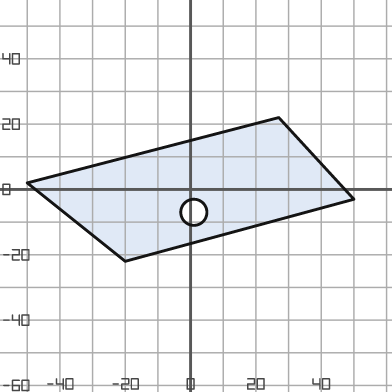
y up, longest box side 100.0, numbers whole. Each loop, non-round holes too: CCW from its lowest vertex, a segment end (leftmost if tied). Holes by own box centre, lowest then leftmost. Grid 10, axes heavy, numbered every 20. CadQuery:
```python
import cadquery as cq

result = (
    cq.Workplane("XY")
    .moveTo(-20.0, -22.0)
    .lineTo(50.0, -3.0)
    .lineTo(27.0, 22.0)
    .lineTo(-50.0, 2.0)
    .close()
    .moveTo(1.0, -7.0)
    .circle(4.0)
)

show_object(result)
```